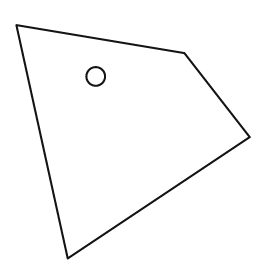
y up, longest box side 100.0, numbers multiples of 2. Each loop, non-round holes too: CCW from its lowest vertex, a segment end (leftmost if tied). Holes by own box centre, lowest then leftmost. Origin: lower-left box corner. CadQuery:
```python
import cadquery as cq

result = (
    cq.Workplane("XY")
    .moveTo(22.0, 0.0)
    .lineTo(100.0, 52.0)
    .lineTo(72.0, 88.0)
    .lineTo(0.0, 100.0)
    .close()
    .moveTo(34.0, 78.0)
    .circle(4.0)
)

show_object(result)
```